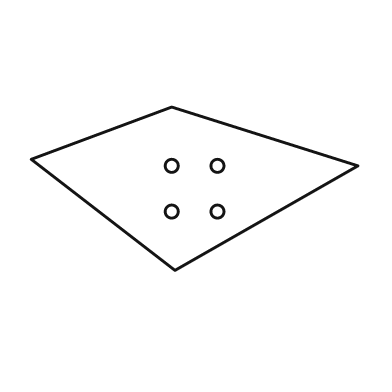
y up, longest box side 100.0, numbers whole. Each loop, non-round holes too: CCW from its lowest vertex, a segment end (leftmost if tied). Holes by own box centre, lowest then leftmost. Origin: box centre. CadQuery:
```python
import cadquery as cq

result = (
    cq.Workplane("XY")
    .moveTo(-6.0, -25.0)
    .lineTo(50.0, 7.0)
    .lineTo(-7.0, 25.0)
    .lineTo(-50.0, 9.0)
    .close()
    .moveTo(-7.0, -7.0)
    .circle(2.0)
    .moveTo(7.0, -7.0)
    .circle(2.0)
    .moveTo(-7.0, 7.0)
    .circle(2.0)
    .moveTo(7.0, 7.0)
    .circle(2.0)
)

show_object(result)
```